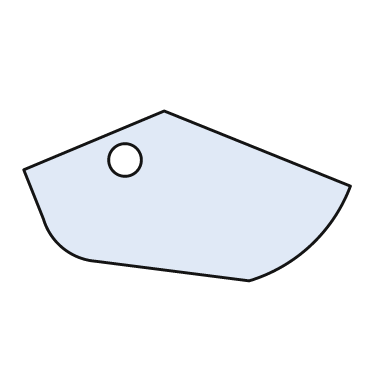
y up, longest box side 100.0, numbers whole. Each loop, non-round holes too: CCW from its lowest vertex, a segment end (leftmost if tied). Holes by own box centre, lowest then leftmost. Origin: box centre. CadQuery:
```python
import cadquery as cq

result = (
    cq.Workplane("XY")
    .moveTo(19.0, -26.0)
    .threePointArc((38.0, -15.0), (50.0, 3.0))
    .lineTo(-7.0, 26.0)
    .lineTo(-50.0, 8.0)
    .lineTo(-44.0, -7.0)
    .threePointArc((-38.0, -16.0), (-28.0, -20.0))
    .close()
    .moveTo(-19.0, 11.0)
    .circle(5.0)
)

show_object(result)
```